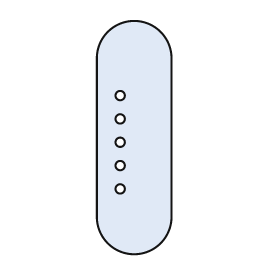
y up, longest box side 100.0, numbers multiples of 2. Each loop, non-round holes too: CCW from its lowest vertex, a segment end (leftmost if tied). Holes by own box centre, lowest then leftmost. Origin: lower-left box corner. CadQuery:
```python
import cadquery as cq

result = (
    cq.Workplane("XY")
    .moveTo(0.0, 16.0)
    .threePointArc((16.0, 0.0), (32.0, 16.0))
    .lineTo(32.0, 84.0)
    .threePointArc((16.0, 100.0), (0.0, 84.0))
    .close()
    .moveTo(10.0, 28.0)
    .circle(2.0)
    .moveTo(10.0, 38.0)
    .circle(2.0)
    .moveTo(10.0, 48.0)
    .circle(2.0)
    .moveTo(10.0, 58.0)
    .circle(2.0)
    .moveTo(10.0, 68.0)
    .circle(2.0)
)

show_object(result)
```